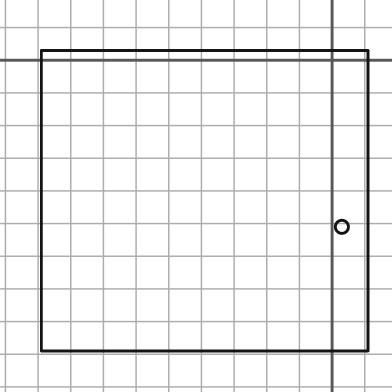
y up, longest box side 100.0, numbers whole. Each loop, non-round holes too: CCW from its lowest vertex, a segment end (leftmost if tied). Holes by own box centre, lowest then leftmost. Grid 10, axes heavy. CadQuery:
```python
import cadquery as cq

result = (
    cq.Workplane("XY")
    .moveTo(-89.0, -89.0)
    .lineTo(11.0, -89.0)
    .lineTo(11.0, 3.0)
    .lineTo(-89.0, 3.0)
    .close()
    .moveTo(3.0, -51.0)
    .circle(2.0)
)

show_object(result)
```